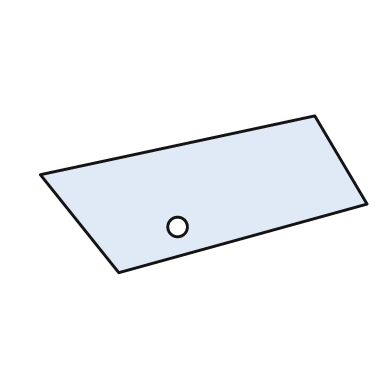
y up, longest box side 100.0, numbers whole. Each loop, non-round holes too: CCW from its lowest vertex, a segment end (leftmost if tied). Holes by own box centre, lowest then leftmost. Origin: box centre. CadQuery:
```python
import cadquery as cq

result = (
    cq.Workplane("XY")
    .moveTo(-26.0, -24.0)
    .lineTo(50.0, -3.0)
    .lineTo(34.0, 24.0)
    .lineTo(-50.0, 6.0)
    .close()
    .moveTo(-8.0, -10.0)
    .circle(3.0)
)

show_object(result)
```